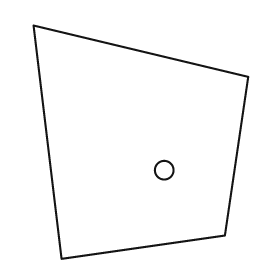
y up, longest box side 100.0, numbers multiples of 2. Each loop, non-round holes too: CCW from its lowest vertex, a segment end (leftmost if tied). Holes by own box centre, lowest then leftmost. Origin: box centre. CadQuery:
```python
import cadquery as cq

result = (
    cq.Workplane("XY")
    .moveTo(-34.0, -50.0)
    .lineTo(36.0, -40.0)
    .lineTo(46.0, 28.0)
    .lineTo(-46.0, 50.0)
    .close()
    .moveTo(10.0, -12.0)
    .circle(4.0)
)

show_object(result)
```